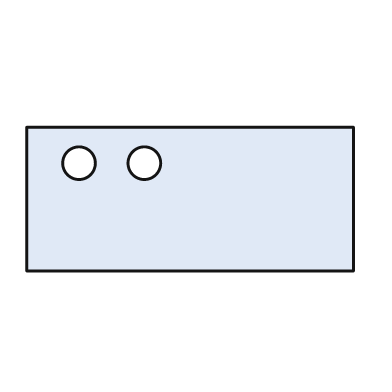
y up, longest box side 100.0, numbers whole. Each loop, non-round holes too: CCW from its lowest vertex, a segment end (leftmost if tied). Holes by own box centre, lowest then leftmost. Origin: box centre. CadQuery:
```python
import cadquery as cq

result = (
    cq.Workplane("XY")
    .moveTo(-50.0, -22.0)
    .lineTo(50.0, -22.0)
    .lineTo(50.0, 22.0)
    .lineTo(-50.0, 22.0)
    .close()
    .moveTo(-34.0, 11.0)
    .circle(5.0)
    .moveTo(-14.0, 11.0)
    .circle(5.0)
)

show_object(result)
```